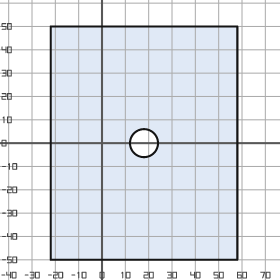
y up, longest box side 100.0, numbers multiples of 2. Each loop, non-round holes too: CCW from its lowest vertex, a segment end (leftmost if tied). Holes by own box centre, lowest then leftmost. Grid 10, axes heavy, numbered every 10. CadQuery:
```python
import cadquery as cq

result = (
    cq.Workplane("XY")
    .moveTo(-22.0, -50.0)
    .lineTo(58.0, -50.0)
    .lineTo(58.0, 50.0)
    .lineTo(-22.0, 50.0)
    .close()
    .moveTo(18.0, 0.0)
    .circle(6.0)
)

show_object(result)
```